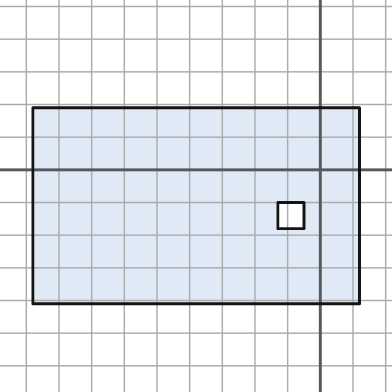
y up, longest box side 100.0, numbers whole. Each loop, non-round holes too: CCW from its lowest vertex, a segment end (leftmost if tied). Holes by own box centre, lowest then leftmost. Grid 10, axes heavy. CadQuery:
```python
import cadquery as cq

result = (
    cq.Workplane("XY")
    .moveTo(-88.0, -41.0)
    .lineTo(12.0, -41.0)
    .lineTo(12.0, 19.0)
    .lineTo(-88.0, 19.0)
    .close()
    .moveTo(-13.0, -18.0)
    .lineTo(-5.0, -18.0)
    .lineTo(-5.0, -10.0)
    .lineTo(-13.0, -10.0)
    .close()
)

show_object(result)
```